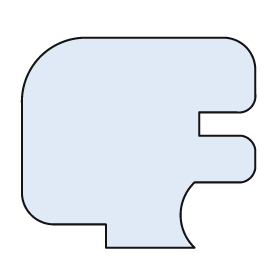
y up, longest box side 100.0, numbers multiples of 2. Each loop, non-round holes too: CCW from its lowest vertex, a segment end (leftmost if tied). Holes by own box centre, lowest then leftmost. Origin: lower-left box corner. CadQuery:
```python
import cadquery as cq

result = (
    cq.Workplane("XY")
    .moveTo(36.0, 0.0)
    .lineTo(74.0, 0.0)
    .threePointArc((68.0, 14.0), (74.0, 28.0))
    .lineTo(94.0, 28.0)
    .threePointArc((98.0, 30.0), (100.0, 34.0))
    .lineTo(100.0, 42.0)
    .threePointArc((98.0, 46.0), (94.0, 48.0))
    .lineTo(76.0, 48.0)
    .lineTo(76.0, 58.0)
    .lineTo(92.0, 58.0)
    .threePointArc((98.0, 60.0), (100.0, 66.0))
    .lineTo(100.0, 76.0)
    .threePointArc((96.0, 86.0), (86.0, 90.0))
    .lineTo(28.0, 90.0)
    .threePointArc((8.0, 82.0), (0.0, 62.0))
    .lineTo(0.0, 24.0)
    .threePointArc((4.0, 14.0), (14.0, 10.0))
    .lineTo(36.0, 10.0)
    .close()
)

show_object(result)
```